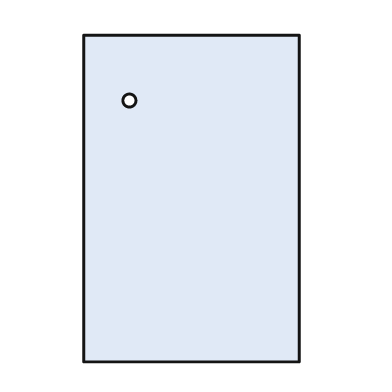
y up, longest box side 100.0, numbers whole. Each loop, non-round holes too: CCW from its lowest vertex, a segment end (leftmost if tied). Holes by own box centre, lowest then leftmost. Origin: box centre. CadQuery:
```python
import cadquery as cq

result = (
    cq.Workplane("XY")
    .moveTo(-33.0, -50.0)
    .lineTo(33.0, -50.0)
    .lineTo(33.0, 50.0)
    .lineTo(-33.0, 50.0)
    .close()
    .moveTo(-19.0, 30.0)
    .circle(2.0)
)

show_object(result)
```